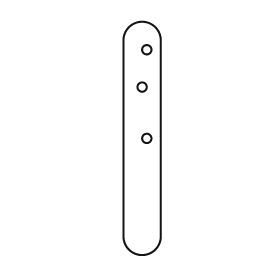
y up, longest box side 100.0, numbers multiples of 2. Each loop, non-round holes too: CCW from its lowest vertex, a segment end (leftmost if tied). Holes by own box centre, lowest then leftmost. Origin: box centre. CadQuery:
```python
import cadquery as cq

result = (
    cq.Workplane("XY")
    .moveTo(-8.0, -42.0)
    .threePointArc((0.0, -50.0), (8.0, -42.0))
    .lineTo(8.0, 42.0)
    .threePointArc((0.0, 50.0), (-8.0, 42.0))
    .close()
    .moveTo(2.0, 0.0)
    .circle(2.0)
    .moveTo(0.0, 22.0)
    .circle(2.0)
    .moveTo(2.0, 38.0)
    .circle(2.0)
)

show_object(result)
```